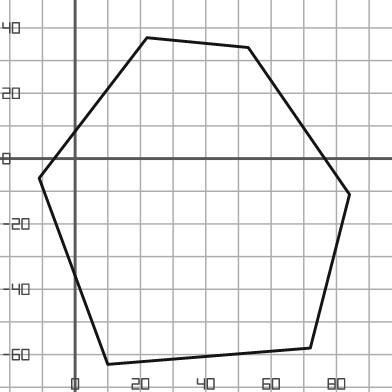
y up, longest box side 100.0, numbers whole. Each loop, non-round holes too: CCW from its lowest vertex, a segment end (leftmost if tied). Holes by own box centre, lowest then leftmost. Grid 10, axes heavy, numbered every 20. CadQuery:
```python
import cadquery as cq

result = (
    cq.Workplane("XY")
    .moveTo(10.0, -63.0)
    .lineTo(72.0, -58.0)
    .lineTo(84.0, -11.0)
    .lineTo(53.0, 34.0)
    .lineTo(22.0, 37.0)
    .lineTo(-11.0, -6.0)
    .close()
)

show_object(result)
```